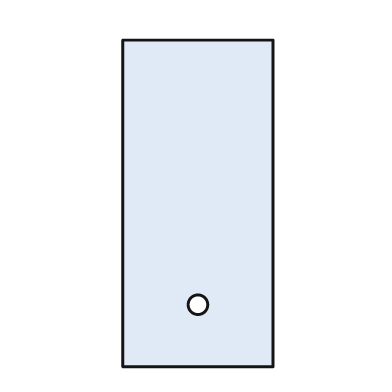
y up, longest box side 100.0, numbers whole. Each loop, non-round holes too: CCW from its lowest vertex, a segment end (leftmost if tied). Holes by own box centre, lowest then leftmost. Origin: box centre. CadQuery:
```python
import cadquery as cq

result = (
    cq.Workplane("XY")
    .moveTo(-23.0, -50.0)
    .lineTo(23.0, -50.0)
    .lineTo(23.0, 50.0)
    .lineTo(-23.0, 50.0)
    .close()
    .moveTo(0.0, -31.0)
    .circle(3.0)
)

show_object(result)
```